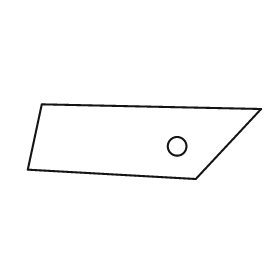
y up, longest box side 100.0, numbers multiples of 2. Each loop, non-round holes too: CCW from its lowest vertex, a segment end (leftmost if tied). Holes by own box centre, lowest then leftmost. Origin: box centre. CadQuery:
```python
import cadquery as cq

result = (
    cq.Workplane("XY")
    .moveTo(22.0, -16.0)
    .lineTo(50.0, 14.0)
    .lineTo(-44.0, 16.0)
    .lineTo(-50.0, -12.0)
    .close()
    .moveTo(14.0, -2.0)
    .circle(4.0)
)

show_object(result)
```